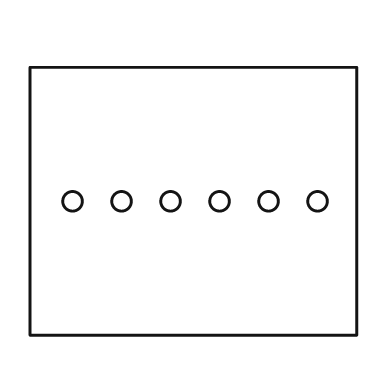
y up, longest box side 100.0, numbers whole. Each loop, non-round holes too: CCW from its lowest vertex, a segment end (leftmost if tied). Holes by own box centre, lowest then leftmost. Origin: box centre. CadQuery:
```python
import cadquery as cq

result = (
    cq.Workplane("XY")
    .moveTo(-50.0, -41.0)
    .lineTo(50.0, -41.0)
    .lineTo(50.0, 41.0)
    .lineTo(-50.0, 41.0)
    .close()
    .moveTo(-37.0, 0.0)
    .circle(3.0)
    .moveTo(-22.0, 0.0)
    .circle(3.0)
    .moveTo(-7.0, 0.0)
    .circle(3.0)
    .moveTo(8.0, 0.0)
    .circle(3.0)
    .moveTo(23.0, 0.0)
    .circle(3.0)
    .moveTo(38.0, 0.0)
    .circle(3.0)
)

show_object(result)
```